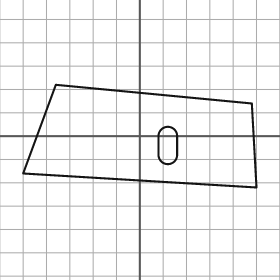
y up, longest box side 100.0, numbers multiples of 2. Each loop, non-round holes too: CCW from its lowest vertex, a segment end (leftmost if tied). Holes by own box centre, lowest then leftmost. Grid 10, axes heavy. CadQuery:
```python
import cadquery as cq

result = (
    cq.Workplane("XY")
    .moveTo(50.0, -22.0)
    .lineTo(48.0, 14.0)
    .lineTo(-36.0, 22.0)
    .lineTo(-50.0, -16.0)
    .close()
    .moveTo(8.0, -8.0)
    .threePointArc((12.0, -12.0), (16.0, -8.0))
    .lineTo(16.0, 0.0)
    .threePointArc((12.0, 4.0), (8.0, 0.0))
    .close()
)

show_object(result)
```